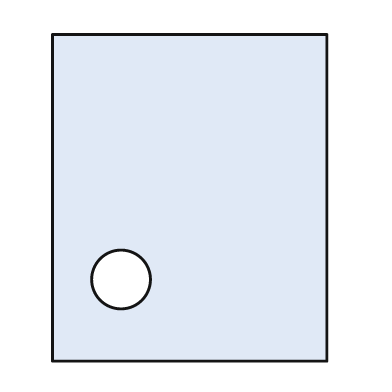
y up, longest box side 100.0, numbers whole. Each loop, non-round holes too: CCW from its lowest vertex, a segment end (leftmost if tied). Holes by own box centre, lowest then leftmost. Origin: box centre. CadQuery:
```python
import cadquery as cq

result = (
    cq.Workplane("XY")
    .moveTo(-42.0, -50.0)
    .lineTo(42.0, -50.0)
    .lineTo(42.0, 50.0)
    .lineTo(-42.0, 50.0)
    .close()
    .moveTo(-21.0, -25.0)
    .circle(9.0)
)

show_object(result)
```